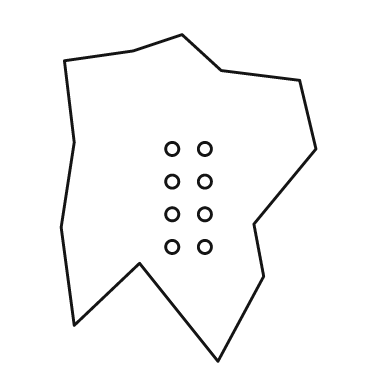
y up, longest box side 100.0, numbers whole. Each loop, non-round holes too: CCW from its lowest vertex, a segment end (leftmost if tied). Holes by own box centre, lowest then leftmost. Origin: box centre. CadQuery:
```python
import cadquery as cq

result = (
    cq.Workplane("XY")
    .moveTo(9.0, -50.0)
    .lineTo(23.0, -24.0)
    .lineTo(20.0, -8.0)
    .lineTo(39.0, 15.0)
    .lineTo(34.0, 36.0)
    .lineTo(10.0, 39.0)
    .lineTo(-2.0, 50.0)
    .lineTo(-17.0, 45.0)
    .lineTo(-38.0, 42.0)
    .lineTo(-35.0, 17.0)
    .lineTo(-39.0, -9.0)
    .lineTo(-35.0, -39.0)
    .lineTo(-15.0, -20.0)
    .close()
    .moveTo(-5.0, -15.0)
    .circle(2.0)
    .moveTo(5.0, -15.0)
    .circle(2.0)
    .moveTo(-5.0, -5.0)
    .circle(2.0)
    .moveTo(5.0, -5.0)
    .circle(2.0)
    .moveTo(-5.0, 5.0)
    .circle(2.0)
    .moveTo(5.0, 5.0)
    .circle(2.0)
    .moveTo(-5.0, 15.0)
    .circle(2.0)
    .moveTo(5.0, 15.0)
    .circle(2.0)
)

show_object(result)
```